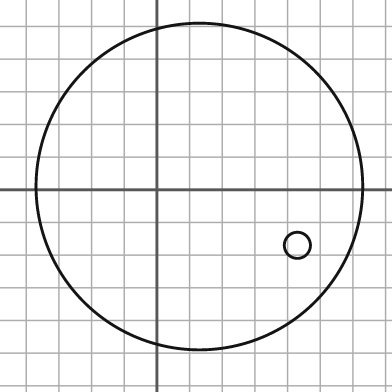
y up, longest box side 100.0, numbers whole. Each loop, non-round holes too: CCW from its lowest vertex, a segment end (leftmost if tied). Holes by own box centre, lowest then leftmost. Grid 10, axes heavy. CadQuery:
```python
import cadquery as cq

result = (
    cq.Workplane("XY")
    .moveTo(13.0, 1.0)
    .circle(50.0)
    .moveTo(43.0, -17.0)
    .circle(4.0)
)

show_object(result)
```